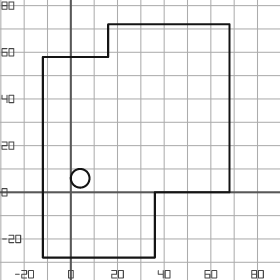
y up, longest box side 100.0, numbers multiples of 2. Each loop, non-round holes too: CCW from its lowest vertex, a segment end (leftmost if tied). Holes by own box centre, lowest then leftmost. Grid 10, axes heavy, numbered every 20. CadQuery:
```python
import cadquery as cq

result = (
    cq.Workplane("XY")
    .moveTo(-12.0, -28.0)
    .lineTo(36.0, -28.0)
    .lineTo(36.0, 0.0)
    .lineTo(68.0, 0.0)
    .lineTo(68.0, 72.0)
    .lineTo(16.0, 72.0)
    .lineTo(16.0, 58.0)
    .lineTo(-12.0, 58.0)
    .close()
    .moveTo(4.0, 6.0)
    .circle(4.0)
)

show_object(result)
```